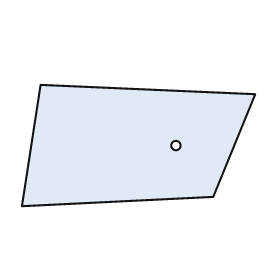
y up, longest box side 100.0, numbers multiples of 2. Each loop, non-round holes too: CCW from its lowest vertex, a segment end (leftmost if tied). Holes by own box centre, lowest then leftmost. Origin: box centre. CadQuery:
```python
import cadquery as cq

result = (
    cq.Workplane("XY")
    .moveTo(-50.0, -26.0)
    .lineTo(32.0, -22.0)
    .lineTo(50.0, 22.0)
    .lineTo(-42.0, 26.0)
    .close()
    .moveTo(16.0, 0.0)
    .circle(2.0)
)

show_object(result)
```